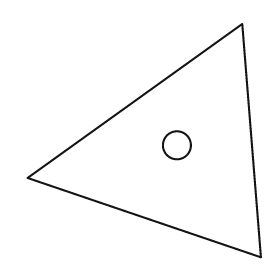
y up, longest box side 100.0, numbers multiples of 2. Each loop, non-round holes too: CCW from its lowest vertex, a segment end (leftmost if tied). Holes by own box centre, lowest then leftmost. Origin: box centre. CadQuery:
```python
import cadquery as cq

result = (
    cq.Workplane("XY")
    .moveTo(50.0, -50.0)
    .lineTo(42.0, 50.0)
    .lineTo(-50.0, -16.0)
    .close()
    .moveTo(14.0, -2.0)
    .circle(6.0)
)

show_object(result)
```